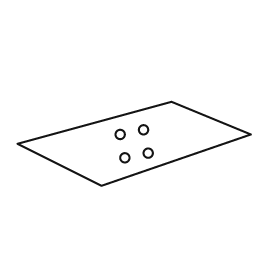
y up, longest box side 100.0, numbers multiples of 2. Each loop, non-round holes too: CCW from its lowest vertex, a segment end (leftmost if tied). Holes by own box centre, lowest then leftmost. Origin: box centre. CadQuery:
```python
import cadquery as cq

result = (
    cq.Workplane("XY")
    .moveTo(-14.0, -18.0)
    .lineTo(50.0, 4.0)
    .lineTo(16.0, 18.0)
    .lineTo(-50.0, 0.0)
    .close()
    .moveTo(-4.0, -6.0)
    .circle(2.0)
    .moveTo(6.0, -4.0)
    .circle(2.0)
    .moveTo(-6.0, 4.0)
    .circle(2.0)
    .moveTo(4.0, 6.0)
    .circle(2.0)
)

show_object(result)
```